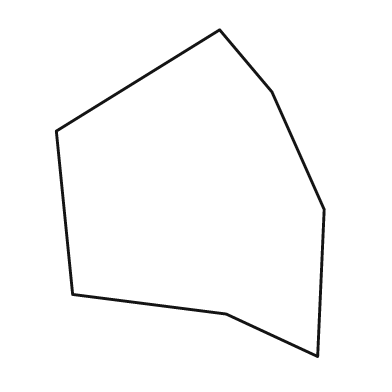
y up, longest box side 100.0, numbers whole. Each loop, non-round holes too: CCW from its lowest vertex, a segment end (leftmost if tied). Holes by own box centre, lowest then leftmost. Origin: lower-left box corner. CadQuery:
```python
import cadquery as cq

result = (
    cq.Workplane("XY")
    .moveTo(80.0, 0.0)
    .lineTo(82.0, 45.0)
    .lineTo(66.0, 81.0)
    .lineTo(50.0, 100.0)
    .lineTo(0.0, 69.0)
    .lineTo(5.0, 19.0)
    .lineTo(52.0, 13.0)
    .close()
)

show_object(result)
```